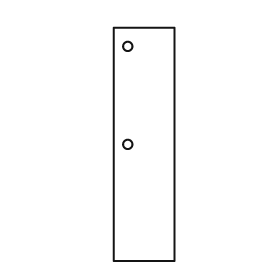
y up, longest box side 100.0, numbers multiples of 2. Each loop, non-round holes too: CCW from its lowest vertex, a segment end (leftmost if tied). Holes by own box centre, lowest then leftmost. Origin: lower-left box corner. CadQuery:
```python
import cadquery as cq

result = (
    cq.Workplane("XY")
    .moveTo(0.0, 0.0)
    .lineTo(26.0, 0.0)
    .lineTo(26.0, 100.0)
    .lineTo(0.0, 100.0)
    .close()
    .moveTo(6.0, 50.0)
    .circle(2.0)
    .moveTo(6.0, 92.0)
    .circle(2.0)
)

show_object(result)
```